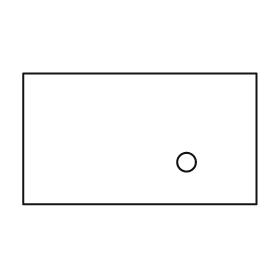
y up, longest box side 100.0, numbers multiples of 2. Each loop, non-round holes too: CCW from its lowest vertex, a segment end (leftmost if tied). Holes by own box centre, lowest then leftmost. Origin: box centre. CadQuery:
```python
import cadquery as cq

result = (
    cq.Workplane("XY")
    .moveTo(-50.0, -28.0)
    .lineTo(50.0, -28.0)
    .lineTo(50.0, 28.0)
    .lineTo(-50.0, 28.0)
    .close()
    .moveTo(20.0, -10.0)
    .circle(4.0)
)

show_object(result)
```